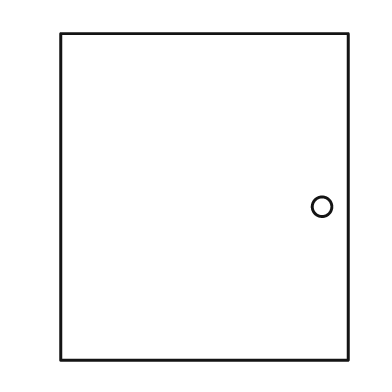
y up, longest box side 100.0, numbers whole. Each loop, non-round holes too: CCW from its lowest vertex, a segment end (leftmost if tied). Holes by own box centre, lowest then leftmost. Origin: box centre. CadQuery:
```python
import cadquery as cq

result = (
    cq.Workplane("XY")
    .moveTo(-44.0, -50.0)
    .lineTo(44.0, -50.0)
    .lineTo(44.0, 50.0)
    .lineTo(-44.0, 50.0)
    .close()
    .moveTo(36.0, -3.0)
    .circle(3.0)
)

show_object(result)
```